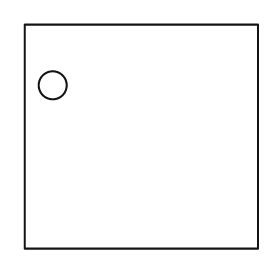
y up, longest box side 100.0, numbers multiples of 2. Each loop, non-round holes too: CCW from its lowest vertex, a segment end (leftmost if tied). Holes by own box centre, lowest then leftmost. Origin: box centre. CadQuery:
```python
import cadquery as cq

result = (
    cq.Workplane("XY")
    .moveTo(-50.0, -48.0)
    .lineTo(50.0, -48.0)
    .lineTo(50.0, 48.0)
    .lineTo(-50.0, 48.0)
    .close()
    .moveTo(-38.0, 22.0)
    .circle(6.0)
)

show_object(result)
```